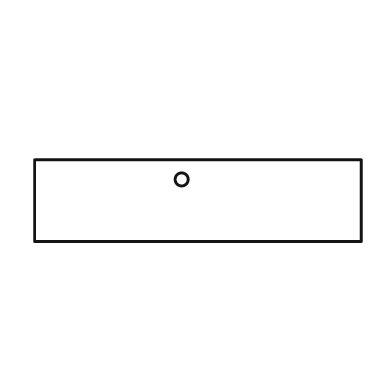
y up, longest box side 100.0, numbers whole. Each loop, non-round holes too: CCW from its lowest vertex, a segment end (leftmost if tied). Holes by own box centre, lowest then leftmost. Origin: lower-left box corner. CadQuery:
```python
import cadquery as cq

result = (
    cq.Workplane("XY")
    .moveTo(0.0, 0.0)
    .lineTo(100.0, 0.0)
    .lineTo(100.0, 25.0)
    .lineTo(0.0, 25.0)
    .close()
    .moveTo(45.0, 19.0)
    .circle(2.0)
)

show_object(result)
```